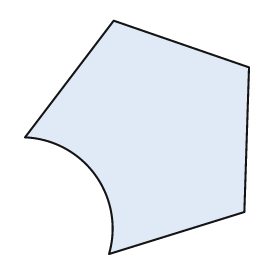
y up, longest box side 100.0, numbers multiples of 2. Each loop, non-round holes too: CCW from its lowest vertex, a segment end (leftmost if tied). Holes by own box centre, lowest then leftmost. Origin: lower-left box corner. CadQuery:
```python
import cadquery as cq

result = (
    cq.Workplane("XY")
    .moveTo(36.0, 0.0)
    .lineTo(94.0, 18.0)
    .lineTo(96.0, 80.0)
    .lineTo(38.0, 100.0)
    .lineTo(0.0, 50.0)
    .threePointArc((30.0, 34.0), (36.0, 0.0))
    .close()
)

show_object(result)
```